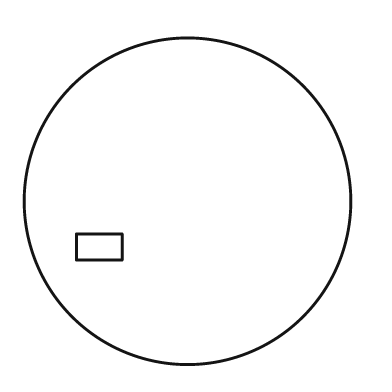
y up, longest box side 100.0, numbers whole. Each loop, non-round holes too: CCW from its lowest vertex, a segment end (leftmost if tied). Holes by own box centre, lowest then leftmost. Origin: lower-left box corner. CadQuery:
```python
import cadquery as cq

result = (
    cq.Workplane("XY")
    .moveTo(50.0, 50.0)
    .circle(50.0)
    .moveTo(16.0, 32.0)
    .lineTo(30.0, 32.0)
    .lineTo(30.0, 40.0)
    .lineTo(16.0, 40.0)
    .close()
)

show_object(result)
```